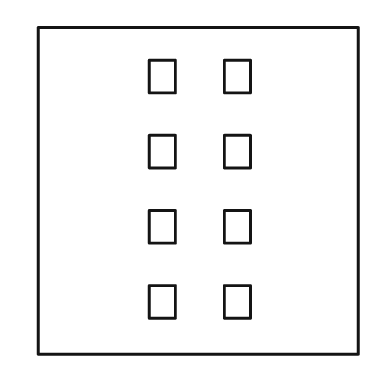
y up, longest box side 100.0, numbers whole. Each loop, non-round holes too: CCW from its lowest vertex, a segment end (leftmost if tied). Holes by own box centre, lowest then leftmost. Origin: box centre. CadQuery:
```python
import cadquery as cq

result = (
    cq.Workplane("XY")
    .moveTo(-49.0, -50.0)
    .lineTo(49.0, -50.0)
    .lineTo(49.0, 50.0)
    .lineTo(-49.0, 50.0)
    .close()
    .moveTo(-15.0, -39.0)
    .lineTo(-7.0, -39.0)
    .lineTo(-7.0, -29.0)
    .lineTo(-15.0, -29.0)
    .close()
    .moveTo(8.0, -39.0)
    .lineTo(16.0, -39.0)
    .lineTo(16.0, -29.0)
    .lineTo(8.0, -29.0)
    .close()
    .moveTo(-15.0, -16.0)
    .lineTo(-7.0, -16.0)
    .lineTo(-7.0, -6.0)
    .lineTo(-15.0, -6.0)
    .close()
    .moveTo(8.0, -16.0)
    .lineTo(16.0, -16.0)
    .lineTo(16.0, -6.0)
    .lineTo(8.0, -6.0)
    .close()
    .moveTo(-15.0, 7.0)
    .lineTo(-7.0, 7.0)
    .lineTo(-7.0, 17.0)
    .lineTo(-15.0, 17.0)
    .close()
    .moveTo(8.0, 7.0)
    .lineTo(16.0, 7.0)
    .lineTo(16.0, 17.0)
    .lineTo(8.0, 17.0)
    .close()
    .moveTo(-15.0, 30.0)
    .lineTo(-7.0, 30.0)
    .lineTo(-7.0, 40.0)
    .lineTo(-15.0, 40.0)
    .close()
    .moveTo(8.0, 30.0)
    .lineTo(16.0, 30.0)
    .lineTo(16.0, 40.0)
    .lineTo(8.0, 40.0)
    .close()
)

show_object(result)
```